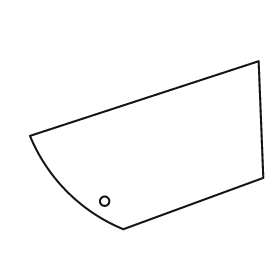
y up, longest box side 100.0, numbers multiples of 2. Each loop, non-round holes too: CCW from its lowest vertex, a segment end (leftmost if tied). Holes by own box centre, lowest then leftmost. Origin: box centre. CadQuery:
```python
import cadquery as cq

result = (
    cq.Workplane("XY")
    .moveTo(-10.0, -36.0)
    .lineTo(50.0, -14.0)
    .lineTo(48.0, 36.0)
    .lineTo(-50.0, 4.0)
    .threePointArc((-34.0, -20.0), (-10.0, -36.0))
    .close()
    .moveTo(-18.0, -24.0)
    .circle(2.0)
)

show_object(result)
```